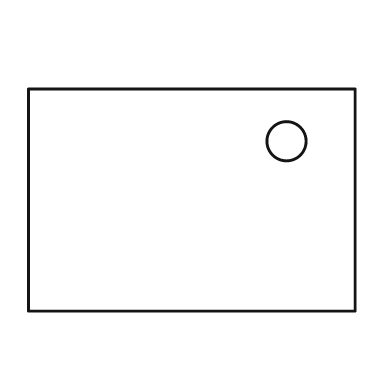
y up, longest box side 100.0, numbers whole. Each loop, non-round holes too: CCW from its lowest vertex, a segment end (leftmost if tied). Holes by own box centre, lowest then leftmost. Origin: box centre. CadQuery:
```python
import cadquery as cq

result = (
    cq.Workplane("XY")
    .moveTo(-50.0, -34.0)
    .lineTo(50.0, -34.0)
    .lineTo(50.0, 34.0)
    .lineTo(-50.0, 34.0)
    .close()
    .moveTo(29.0, 18.0)
    .circle(6.0)
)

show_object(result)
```